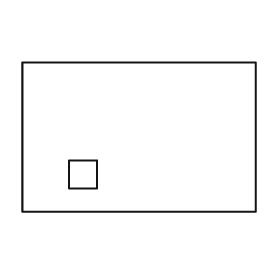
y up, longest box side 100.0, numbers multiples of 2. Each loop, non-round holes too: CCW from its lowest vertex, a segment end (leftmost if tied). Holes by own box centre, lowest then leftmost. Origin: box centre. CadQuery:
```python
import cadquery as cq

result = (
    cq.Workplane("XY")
    .moveTo(-50.0, -32.0)
    .lineTo(50.0, -32.0)
    .lineTo(50.0, 32.0)
    .lineTo(-50.0, 32.0)
    .close()
    .moveTo(-30.0, -22.0)
    .lineTo(-18.0, -22.0)
    .lineTo(-18.0, -10.0)
    .lineTo(-30.0, -10.0)
    .close()
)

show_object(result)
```